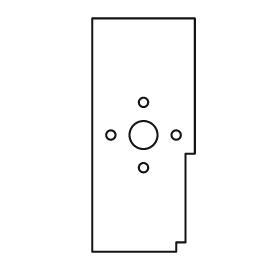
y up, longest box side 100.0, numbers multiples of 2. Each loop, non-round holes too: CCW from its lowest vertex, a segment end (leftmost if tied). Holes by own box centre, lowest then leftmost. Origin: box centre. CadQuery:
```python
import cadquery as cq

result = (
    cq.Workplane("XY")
    .moveTo(-22.0, -50.0)
    .lineTo(14.0, -50.0)
    .lineTo(14.0, -46.0)
    .lineTo(18.0, -46.0)
    .lineTo(18.0, -8.0)
    .lineTo(22.0, -8.0)
    .lineTo(22.0, 50.0)
    .lineTo(-22.0, 50.0)
    .close()
    .moveTo(0.0, -14.0)
    .circle(2.0)
    .moveTo(-14.0, 0.0)
    .circle(2.0)
    .moveTo(0.0, 0.0)
    .circle(6.0)
    .moveTo(14.0, 0.0)
    .circle(2.0)
    .moveTo(0.0, 14.0)
    .circle(2.0)
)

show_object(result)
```